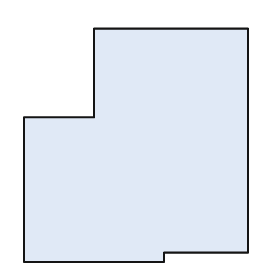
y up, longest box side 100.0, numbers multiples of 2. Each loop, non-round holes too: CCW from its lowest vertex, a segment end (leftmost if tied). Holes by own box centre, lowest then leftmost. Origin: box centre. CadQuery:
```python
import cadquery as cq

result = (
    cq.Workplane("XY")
    .moveTo(-48.0, -50.0)
    .lineTo(12.0, -50.0)
    .lineTo(12.0, -46.0)
    .lineTo(48.0, -46.0)
    .lineTo(48.0, 50.0)
    .lineTo(-18.0, 50.0)
    .lineTo(-18.0, 12.0)
    .lineTo(-48.0, 12.0)
    .close()
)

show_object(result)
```